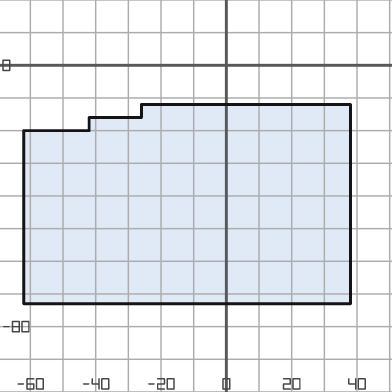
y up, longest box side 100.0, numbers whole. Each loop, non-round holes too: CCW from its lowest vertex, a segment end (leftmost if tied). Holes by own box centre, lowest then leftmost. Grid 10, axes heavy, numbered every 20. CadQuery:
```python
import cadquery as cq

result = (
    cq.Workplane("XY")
    .moveTo(-62.0, -73.0)
    .lineTo(38.0, -73.0)
    .lineTo(38.0, -12.0)
    .lineTo(-26.0, -12.0)
    .lineTo(-26.0, -16.0)
    .lineTo(-42.0, -16.0)
    .lineTo(-42.0, -20.0)
    .lineTo(-62.0, -20.0)
    .close()
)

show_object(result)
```